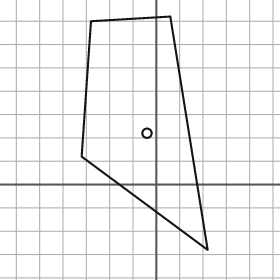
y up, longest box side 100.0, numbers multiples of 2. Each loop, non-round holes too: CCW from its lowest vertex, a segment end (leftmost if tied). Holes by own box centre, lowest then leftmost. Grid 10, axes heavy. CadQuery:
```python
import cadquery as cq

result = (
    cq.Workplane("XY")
    .moveTo(22.0, -28.0)
    .lineTo(6.0, 72.0)
    .lineTo(-28.0, 70.0)
    .lineTo(-32.0, 12.0)
    .close()
    .moveTo(-4.0, 22.0)
    .circle(2.0)
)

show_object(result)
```